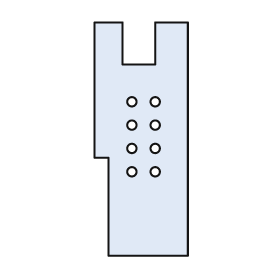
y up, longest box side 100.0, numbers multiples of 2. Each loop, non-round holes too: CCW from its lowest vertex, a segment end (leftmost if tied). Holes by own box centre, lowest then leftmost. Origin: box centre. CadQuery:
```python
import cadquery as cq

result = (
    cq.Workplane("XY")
    .moveTo(-14.0, -50.0)
    .lineTo(20.0, -50.0)
    .lineTo(20.0, 50.0)
    .lineTo(6.0, 50.0)
    .lineTo(6.0, 32.0)
    .lineTo(-8.0, 32.0)
    .lineTo(-8.0, 50.0)
    .lineTo(-20.0, 50.0)
    .lineTo(-20.0, -8.0)
    .lineTo(-14.0, -8.0)
    .close()
    .moveTo(-4.0, -14.0)
    .circle(2.0)
    .moveTo(6.0, -14.0)
    .circle(2.0)
    .moveTo(-4.0, -4.0)
    .circle(2.0)
    .moveTo(6.0, -4.0)
    .circle(2.0)
    .moveTo(-4.0, 6.0)
    .circle(2.0)
    .moveTo(6.0, 6.0)
    .circle(2.0)
    .moveTo(-4.0, 16.0)
    .circle(2.0)
    .moveTo(6.0, 16.0)
    .circle(2.0)
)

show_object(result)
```